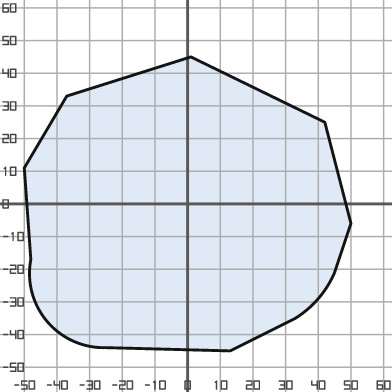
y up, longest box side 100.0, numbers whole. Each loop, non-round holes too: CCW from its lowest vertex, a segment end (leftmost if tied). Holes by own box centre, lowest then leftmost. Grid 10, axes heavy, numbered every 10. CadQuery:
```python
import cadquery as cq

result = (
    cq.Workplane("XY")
    .moveTo(13.0, -45.0)
    .lineTo(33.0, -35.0)
    .threePointArc((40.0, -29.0), (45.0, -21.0))
    .lineTo(50.0, -6.0)
    .lineTo(42.0, 25.0)
    .lineTo(1.0, 45.0)
    .lineTo(-37.0, 33.0)
    .lineTo(-50.0, 11.0)
    .lineTo(-48.0, -17.0)
    .threePointArc((-43.0, -36.0), (-25.0, -44.0))
    .close()
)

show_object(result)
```